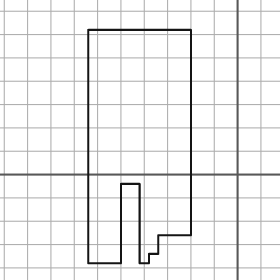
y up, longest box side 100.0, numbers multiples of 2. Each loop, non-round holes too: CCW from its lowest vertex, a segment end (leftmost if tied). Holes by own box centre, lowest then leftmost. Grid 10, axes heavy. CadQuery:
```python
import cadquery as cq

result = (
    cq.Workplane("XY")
    .moveTo(-64.0, -38.0)
    .lineTo(-50.0, -38.0)
    .lineTo(-50.0, -4.0)
    .lineTo(-42.0, -4.0)
    .lineTo(-42.0, -38.0)
    .lineTo(-38.0, -38.0)
    .lineTo(-38.0, -34.0)
    .lineTo(-34.0, -34.0)
    .lineTo(-34.0, -26.0)
    .lineTo(-20.0, -26.0)
    .lineTo(-20.0, 62.0)
    .lineTo(-64.0, 62.0)
    .close()
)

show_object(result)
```